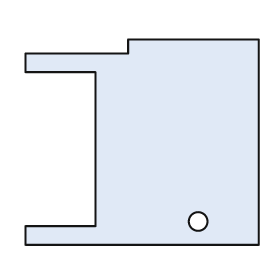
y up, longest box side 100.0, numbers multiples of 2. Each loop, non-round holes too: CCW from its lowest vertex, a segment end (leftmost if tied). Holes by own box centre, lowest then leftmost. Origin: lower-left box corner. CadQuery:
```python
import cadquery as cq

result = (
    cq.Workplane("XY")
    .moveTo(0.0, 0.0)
    .lineTo(100.0, 0.0)
    .lineTo(100.0, 88.0)
    .lineTo(44.0, 88.0)
    .lineTo(44.0, 82.0)
    .lineTo(0.0, 82.0)
    .lineTo(0.0, 74.0)
    .lineTo(30.0, 74.0)
    .lineTo(30.0, 8.0)
    .lineTo(0.0, 8.0)
    .close()
    .moveTo(74.0, 10.0)
    .circle(4.0)
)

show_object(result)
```